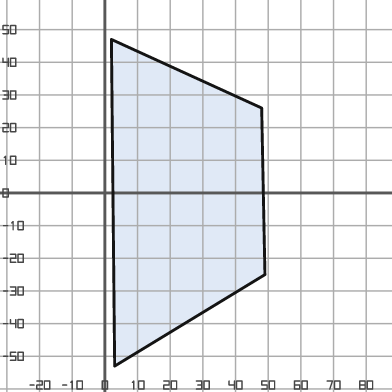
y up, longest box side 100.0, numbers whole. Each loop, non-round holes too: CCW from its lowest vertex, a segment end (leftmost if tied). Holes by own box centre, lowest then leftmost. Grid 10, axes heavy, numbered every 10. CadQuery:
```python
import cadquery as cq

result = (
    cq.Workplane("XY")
    .moveTo(3.0, -53.0)
    .lineTo(49.0, -25.0)
    .lineTo(48.0, 26.0)
    .lineTo(2.0, 47.0)
    .close()
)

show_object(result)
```